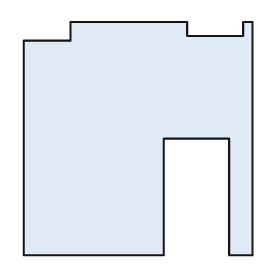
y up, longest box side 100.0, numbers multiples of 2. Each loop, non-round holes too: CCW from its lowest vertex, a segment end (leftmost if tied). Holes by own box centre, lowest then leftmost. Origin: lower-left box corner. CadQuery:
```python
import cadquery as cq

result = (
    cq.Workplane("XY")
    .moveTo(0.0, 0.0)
    .lineTo(60.0, 0.0)
    .lineTo(60.0, 50.0)
    .lineTo(88.0, 50.0)
    .lineTo(88.0, 0.0)
    .lineTo(98.0, 0.0)
    .lineTo(98.0, 100.0)
    .lineTo(94.0, 100.0)
    .lineTo(94.0, 94.0)
    .lineTo(70.0, 94.0)
    .lineTo(70.0, 100.0)
    .lineTo(20.0, 100.0)
    .lineTo(20.0, 92.0)
    .lineTo(0.0, 92.0)
    .close()
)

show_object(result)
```